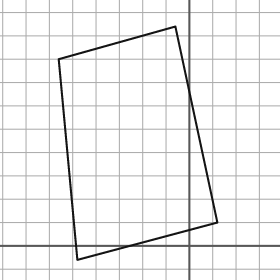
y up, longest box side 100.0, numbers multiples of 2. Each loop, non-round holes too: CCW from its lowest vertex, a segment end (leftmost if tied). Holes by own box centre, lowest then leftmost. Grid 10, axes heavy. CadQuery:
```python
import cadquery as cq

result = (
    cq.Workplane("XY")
    .moveTo(-48.0, -6.0)
    .lineTo(12.0, 10.0)
    .lineTo(-6.0, 94.0)
    .lineTo(-56.0, 80.0)
    .close()
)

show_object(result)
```